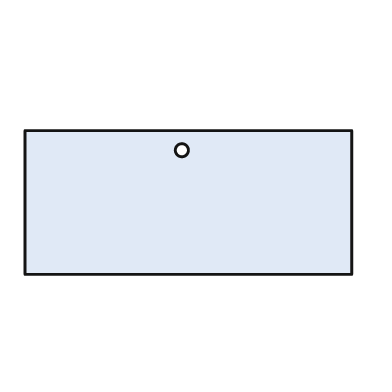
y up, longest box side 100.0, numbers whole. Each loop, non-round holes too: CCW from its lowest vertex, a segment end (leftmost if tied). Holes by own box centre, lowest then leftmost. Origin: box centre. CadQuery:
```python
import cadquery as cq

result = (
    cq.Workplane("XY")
    .moveTo(-50.0, -22.0)
    .lineTo(50.0, -22.0)
    .lineTo(50.0, 22.0)
    .lineTo(-50.0, 22.0)
    .close()
    .moveTo(-2.0, 16.0)
    .circle(2.0)
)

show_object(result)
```